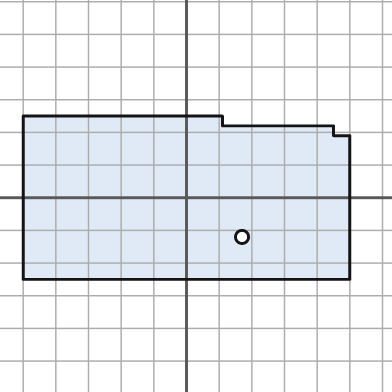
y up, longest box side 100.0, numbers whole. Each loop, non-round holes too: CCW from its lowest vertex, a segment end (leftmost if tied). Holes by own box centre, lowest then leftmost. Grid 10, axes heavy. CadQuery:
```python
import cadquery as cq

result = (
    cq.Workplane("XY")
    .moveTo(-50.0, -25.0)
    .lineTo(50.0, -25.0)
    .lineTo(50.0, 19.0)
    .lineTo(45.0, 19.0)
    .lineTo(45.0, 22.0)
    .lineTo(11.0, 22.0)
    .lineTo(11.0, 25.0)
    .lineTo(-50.0, 25.0)
    .close()
    .moveTo(17.0, -12.0)
    .circle(2.0)
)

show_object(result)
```